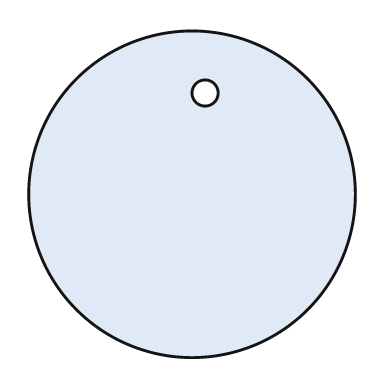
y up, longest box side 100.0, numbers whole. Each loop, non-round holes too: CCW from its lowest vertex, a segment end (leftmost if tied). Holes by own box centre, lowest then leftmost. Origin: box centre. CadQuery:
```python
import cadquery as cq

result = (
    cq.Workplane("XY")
    .moveTo(0.0, 0.0)
    .circle(50.0)
    .moveTo(4.0, 31.0)
    .circle(4.0)
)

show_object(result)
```